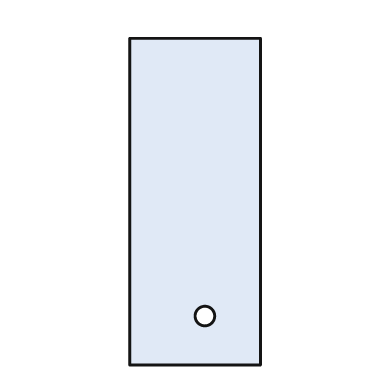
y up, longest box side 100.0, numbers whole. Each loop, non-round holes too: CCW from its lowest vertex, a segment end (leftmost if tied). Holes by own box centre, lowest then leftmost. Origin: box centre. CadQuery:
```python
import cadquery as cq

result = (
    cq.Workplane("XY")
    .moveTo(-20.0, -50.0)
    .lineTo(20.0, -50.0)
    .lineTo(20.0, 50.0)
    .lineTo(-20.0, 50.0)
    .close()
    .moveTo(3.0, -35.0)
    .circle(3.0)
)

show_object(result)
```